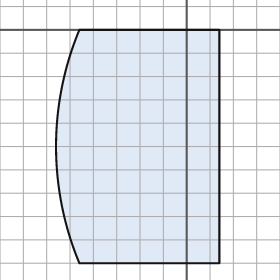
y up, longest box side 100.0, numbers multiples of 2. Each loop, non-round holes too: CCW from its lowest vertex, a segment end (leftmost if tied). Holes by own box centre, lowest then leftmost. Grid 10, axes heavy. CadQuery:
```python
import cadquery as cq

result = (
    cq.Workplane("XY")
    .moveTo(-46.0, -100.0)
    .lineTo(14.0, -100.0)
    .lineTo(14.0, 0.0)
    .lineTo(-46.0, 0.0)
    .threePointArc((-56.0, -50.0), (-46.0, -100.0))
    .close()
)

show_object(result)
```